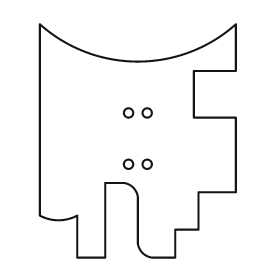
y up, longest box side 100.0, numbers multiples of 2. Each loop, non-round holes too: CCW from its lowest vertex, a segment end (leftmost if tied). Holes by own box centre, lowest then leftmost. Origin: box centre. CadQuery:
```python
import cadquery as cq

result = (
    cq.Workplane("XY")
    .moveTo(-26.0, -50.0)
    .lineTo(-14.0, -50.0)
    .lineTo(-14.0, -18.0)
    .lineTo(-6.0, -18.0)
    .threePointArc((-2.0, -20.0), (0.0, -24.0))
    .lineTo(0.0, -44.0)
    .threePointArc((2.0, -48.0), (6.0, -50.0))
    .lineTo(16.0, -50.0)
    .lineTo(16.0, -38.0)
    .lineTo(26.0, -38.0)
    .lineTo(26.0, -22.0)
    .lineTo(42.0, -22.0)
    .lineTo(42.0, 10.0)
    .lineTo(24.0, 10.0)
    .lineTo(24.0, 30.0)
    .lineTo(42.0, 30.0)
    .lineTo(42.0, 50.0)
    .threePointArc((0.0, 34.0), (-42.0, 50.0))
    .lineTo(-42.0, -32.0)
    .threePointArc((-34.0, -34.0), (-26.0, -32.0))
    .close()
    .moveTo(-4.0, -10.0)
    .circle(2.0)
    .moveTo(4.0, -10.0)
    .circle(2.0)
    .moveTo(-4.0, 12.0)
    .circle(2.0)
    .moveTo(4.0, 12.0)
    .circle(2.0)
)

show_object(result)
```